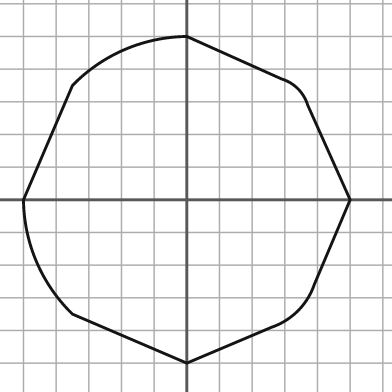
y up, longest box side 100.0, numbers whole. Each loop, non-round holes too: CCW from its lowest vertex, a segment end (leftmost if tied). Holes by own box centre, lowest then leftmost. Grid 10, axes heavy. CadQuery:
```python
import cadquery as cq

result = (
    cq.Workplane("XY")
    .moveTo(0.0, -50.0)
    .lineTo(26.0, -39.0)
    .threePointArc((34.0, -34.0), (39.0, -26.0))
    .lineTo(50.0, 0.0)
    .lineTo(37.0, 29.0)
    .threePointArc((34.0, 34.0), (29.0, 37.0))
    .lineTo(0.0, 50.0)
    .threePointArc((-19.0, 46.0), (-35.0, 35.0))
    .lineTo(-50.0, 0.0)
    .threePointArc((-46.0, -19.0), (-35.0, -35.0))
    .close()
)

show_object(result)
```